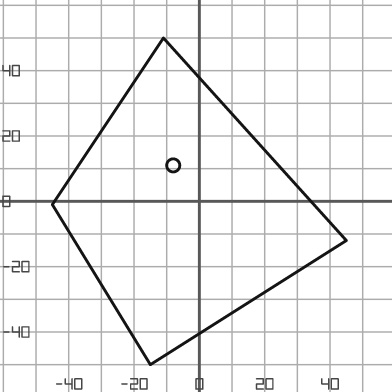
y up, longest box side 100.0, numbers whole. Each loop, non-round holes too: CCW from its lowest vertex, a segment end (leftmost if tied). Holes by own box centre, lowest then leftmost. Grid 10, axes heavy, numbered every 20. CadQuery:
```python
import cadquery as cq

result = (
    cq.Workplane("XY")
    .moveTo(-15.0, -50.0)
    .lineTo(45.0, -12.0)
    .lineTo(-11.0, 50.0)
    .lineTo(-45.0, -1.0)
    .close()
    .moveTo(-8.0, 11.0)
    .circle(2.0)
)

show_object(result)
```